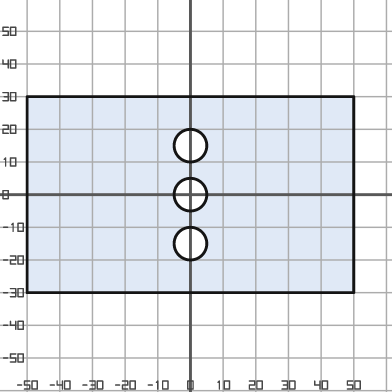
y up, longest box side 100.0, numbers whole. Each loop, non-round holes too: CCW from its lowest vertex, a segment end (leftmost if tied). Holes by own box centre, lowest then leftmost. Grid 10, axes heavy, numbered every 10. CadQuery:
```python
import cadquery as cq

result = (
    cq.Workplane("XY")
    .moveTo(-50.0, -30.0)
    .lineTo(50.0, -30.0)
    .lineTo(50.0, 30.0)
    .lineTo(-50.0, 30.0)
    .close()
    .moveTo(0.0, -15.0)
    .circle(5.0)
    .moveTo(0.0, 0.0)
    .circle(5.0)
    .moveTo(0.0, 15.0)
    .circle(5.0)
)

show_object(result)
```